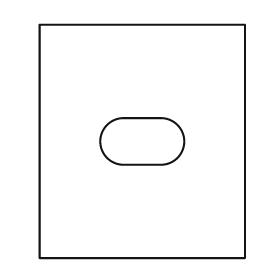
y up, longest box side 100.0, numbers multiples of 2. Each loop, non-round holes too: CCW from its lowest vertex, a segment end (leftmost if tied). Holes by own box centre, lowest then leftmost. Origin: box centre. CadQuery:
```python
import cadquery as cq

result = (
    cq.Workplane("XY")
    .moveTo(-44.0, -50.0)
    .lineTo(44.0, -50.0)
    .lineTo(44.0, 50.0)
    .lineTo(-44.0, 50.0)
    .close()
    .moveTo(-8.0, -10.0)
    .lineTo(8.0, -10.0)
    .threePointArc((18.0, 0.0), (8.0, 10.0))
    .lineTo(-8.0, 10.0)
    .threePointArc((-18.0, 0.0), (-8.0, -10.0))
    .close()
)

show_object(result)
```